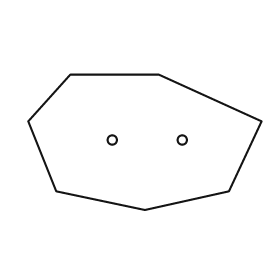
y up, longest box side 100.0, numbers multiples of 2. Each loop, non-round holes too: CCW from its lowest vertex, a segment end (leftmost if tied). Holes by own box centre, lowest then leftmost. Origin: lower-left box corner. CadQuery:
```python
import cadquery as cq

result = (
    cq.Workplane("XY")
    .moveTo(50.0, 0.0)
    .lineTo(86.0, 8.0)
    .lineTo(100.0, 38.0)
    .lineTo(56.0, 58.0)
    .lineTo(18.0, 58.0)
    .lineTo(0.0, 38.0)
    .lineTo(12.0, 8.0)
    .close()
    .moveTo(36.0, 30.0)
    .circle(2.0)
    .moveTo(66.0, 30.0)
    .circle(2.0)
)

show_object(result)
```